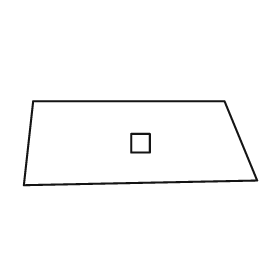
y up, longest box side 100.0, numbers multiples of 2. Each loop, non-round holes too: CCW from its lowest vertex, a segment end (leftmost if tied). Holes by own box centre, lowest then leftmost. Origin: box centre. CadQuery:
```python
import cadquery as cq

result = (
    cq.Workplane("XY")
    .moveTo(-50.0, -18.0)
    .lineTo(50.0, -16.0)
    .lineTo(36.0, 18.0)
    .lineTo(-46.0, 18.0)
    .close()
    .moveTo(-4.0, -4.0)
    .lineTo(4.0, -4.0)
    .lineTo(4.0, 4.0)
    .lineTo(-4.0, 4.0)
    .close()
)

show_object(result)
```